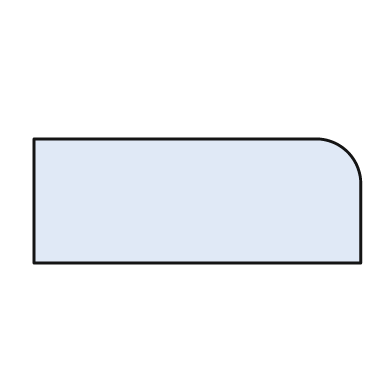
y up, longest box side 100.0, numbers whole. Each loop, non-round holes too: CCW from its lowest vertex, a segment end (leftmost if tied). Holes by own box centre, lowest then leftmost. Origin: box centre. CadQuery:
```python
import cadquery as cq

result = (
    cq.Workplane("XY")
    .moveTo(-50.0, -19.0)
    .lineTo(50.0, -19.0)
    .lineTo(50.0, 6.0)
    .threePointArc((46.0, 15.0), (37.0, 19.0))
    .lineTo(-50.0, 19.0)
    .close()
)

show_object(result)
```